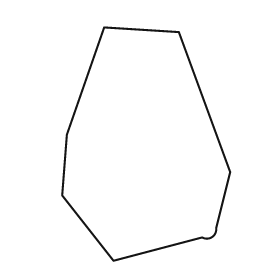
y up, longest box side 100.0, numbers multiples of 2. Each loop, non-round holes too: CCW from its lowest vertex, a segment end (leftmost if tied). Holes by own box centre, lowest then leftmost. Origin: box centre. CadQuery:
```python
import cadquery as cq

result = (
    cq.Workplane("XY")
    .moveTo(-14.0, -50.0)
    .lineTo(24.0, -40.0)
    .threePointArc((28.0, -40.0), (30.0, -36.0))
    .lineTo(36.0, -12.0)
    .lineTo(14.0, 48.0)
    .lineTo(-18.0, 50.0)
    .lineTo(-34.0, 4.0)
    .lineTo(-36.0, -22.0)
    .close()
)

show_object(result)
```